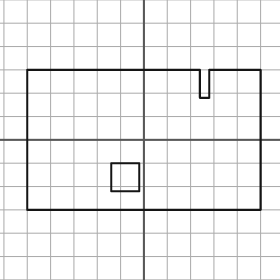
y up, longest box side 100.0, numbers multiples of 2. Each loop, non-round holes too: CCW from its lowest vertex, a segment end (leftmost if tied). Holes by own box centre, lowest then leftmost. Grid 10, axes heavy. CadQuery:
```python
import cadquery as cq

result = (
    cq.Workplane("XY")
    .moveTo(-50.0, -30.0)
    .lineTo(50.0, -30.0)
    .lineTo(50.0, 30.0)
    .lineTo(28.0, 30.0)
    .lineTo(28.0, 18.0)
    .lineTo(24.0, 18.0)
    .lineTo(24.0, 30.0)
    .lineTo(-50.0, 30.0)
    .close()
    .moveTo(-14.0, -22.0)
    .lineTo(-2.0, -22.0)
    .lineTo(-2.0, -10.0)
    .lineTo(-14.0, -10.0)
    .close()
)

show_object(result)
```